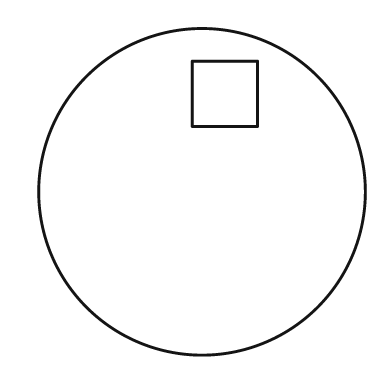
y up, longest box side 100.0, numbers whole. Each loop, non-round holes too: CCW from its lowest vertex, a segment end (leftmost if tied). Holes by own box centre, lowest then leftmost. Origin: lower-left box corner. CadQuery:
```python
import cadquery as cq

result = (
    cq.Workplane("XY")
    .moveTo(50.0, 50.0)
    .circle(50.0)
    .moveTo(47.0, 70.0)
    .lineTo(67.0, 70.0)
    .lineTo(67.0, 90.0)
    .lineTo(47.0, 90.0)
    .close()
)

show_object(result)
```